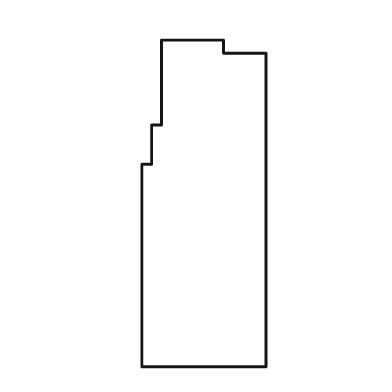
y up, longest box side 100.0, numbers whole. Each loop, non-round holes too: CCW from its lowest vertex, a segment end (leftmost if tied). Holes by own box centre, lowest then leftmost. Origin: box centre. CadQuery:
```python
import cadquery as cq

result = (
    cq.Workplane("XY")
    .moveTo(-19.0, -50.0)
    .lineTo(19.0, -50.0)
    .lineTo(19.0, 46.0)
    .lineTo(6.0, 46.0)
    .lineTo(6.0, 50.0)
    .lineTo(-13.0, 50.0)
    .lineTo(-13.0, 24.0)
    .lineTo(-16.0, 24.0)
    .lineTo(-16.0, 12.0)
    .lineTo(-19.0, 12.0)
    .close()
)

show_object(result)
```